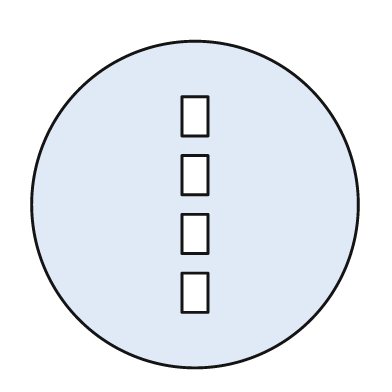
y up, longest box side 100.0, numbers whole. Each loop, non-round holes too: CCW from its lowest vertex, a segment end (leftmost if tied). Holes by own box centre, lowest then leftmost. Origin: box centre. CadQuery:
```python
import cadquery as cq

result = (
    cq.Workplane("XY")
    .moveTo(0.0, 0.0)
    .circle(50.0)
    .moveTo(-4.0, -33.0)
    .lineTo(4.0, -33.0)
    .lineTo(4.0, -21.0)
    .lineTo(-4.0, -21.0)
    .close()
    .moveTo(-4.0, -15.0)
    .lineTo(4.0, -15.0)
    .lineTo(4.0, -3.0)
    .lineTo(-4.0, -3.0)
    .close()
    .moveTo(-4.0, 3.0)
    .lineTo(4.0, 3.0)
    .lineTo(4.0, 15.0)
    .lineTo(-4.0, 15.0)
    .close()
    .moveTo(-4.0, 21.0)
    .lineTo(4.0, 21.0)
    .lineTo(4.0, 33.0)
    .lineTo(-4.0, 33.0)
    .close()
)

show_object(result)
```